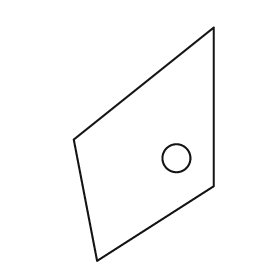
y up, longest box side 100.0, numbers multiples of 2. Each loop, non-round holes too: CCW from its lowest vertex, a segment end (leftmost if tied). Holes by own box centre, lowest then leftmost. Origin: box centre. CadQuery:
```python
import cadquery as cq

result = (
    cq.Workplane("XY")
    .moveTo(-20.0, -50.0)
    .lineTo(30.0, -18.0)
    .lineTo(30.0, 50.0)
    .lineTo(-30.0, 2.0)
    .close()
    .moveTo(14.0, -6.0)
    .circle(6.0)
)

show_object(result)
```